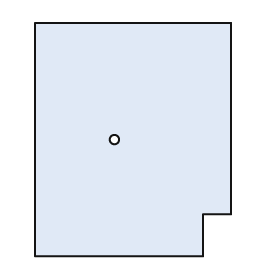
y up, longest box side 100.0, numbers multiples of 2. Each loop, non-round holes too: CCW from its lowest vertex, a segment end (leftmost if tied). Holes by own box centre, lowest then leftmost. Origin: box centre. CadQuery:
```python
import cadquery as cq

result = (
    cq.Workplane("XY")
    .moveTo(-42.0, -50.0)
    .lineTo(30.0, -50.0)
    .lineTo(30.0, -32.0)
    .lineTo(42.0, -32.0)
    .lineTo(42.0, 50.0)
    .lineTo(-42.0, 50.0)
    .close()
    .moveTo(-8.0, 0.0)
    .circle(2.0)
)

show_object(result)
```